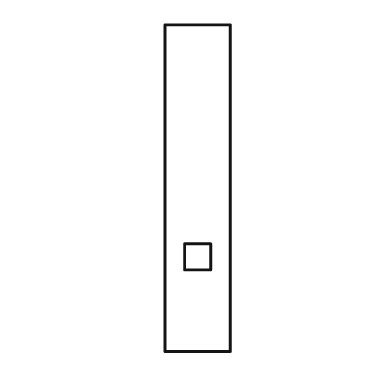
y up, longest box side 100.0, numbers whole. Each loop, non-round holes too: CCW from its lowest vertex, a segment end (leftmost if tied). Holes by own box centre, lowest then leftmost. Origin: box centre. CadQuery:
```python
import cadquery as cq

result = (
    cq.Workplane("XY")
    .moveTo(-10.0, -50.0)
    .lineTo(10.0, -50.0)
    .lineTo(10.0, 50.0)
    .lineTo(-10.0, 50.0)
    .close()
    .moveTo(-4.0, -25.0)
    .lineTo(4.0, -25.0)
    .lineTo(4.0, -17.0)
    .lineTo(-4.0, -17.0)
    .close()
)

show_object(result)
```